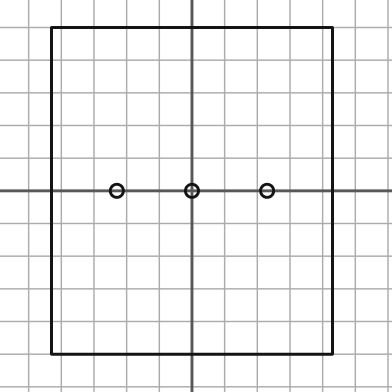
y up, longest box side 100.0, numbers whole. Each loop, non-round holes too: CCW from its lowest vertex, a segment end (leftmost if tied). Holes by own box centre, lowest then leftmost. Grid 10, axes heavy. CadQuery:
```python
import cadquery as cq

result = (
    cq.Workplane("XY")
    .moveTo(-43.0, -50.0)
    .lineTo(43.0, -50.0)
    .lineTo(43.0, 50.0)
    .lineTo(-43.0, 50.0)
    .close()
    .moveTo(-23.0, 0.0)
    .circle(2.0)
    .moveTo(0.0, 0.0)
    .circle(2.0)
    .moveTo(23.0, 0.0)
    .circle(2.0)
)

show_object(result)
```